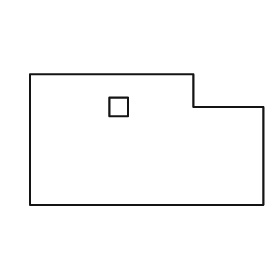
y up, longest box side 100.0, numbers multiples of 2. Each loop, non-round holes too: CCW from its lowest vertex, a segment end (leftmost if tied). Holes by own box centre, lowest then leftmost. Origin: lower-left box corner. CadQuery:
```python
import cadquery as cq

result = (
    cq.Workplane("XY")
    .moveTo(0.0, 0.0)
    .lineTo(100.0, 0.0)
    .lineTo(100.0, 42.0)
    .lineTo(70.0, 42.0)
    .lineTo(70.0, 56.0)
    .lineTo(0.0, 56.0)
    .close()
    .moveTo(34.0, 38.0)
    .lineTo(42.0, 38.0)
    .lineTo(42.0, 46.0)
    .lineTo(34.0, 46.0)
    .close()
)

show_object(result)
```